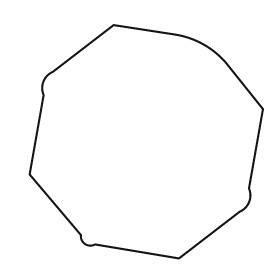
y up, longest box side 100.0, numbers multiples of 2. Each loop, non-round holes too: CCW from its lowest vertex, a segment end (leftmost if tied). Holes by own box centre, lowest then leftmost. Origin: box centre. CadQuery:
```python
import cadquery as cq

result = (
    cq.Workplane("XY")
    .moveTo(14.0, -50.0)
    .lineTo(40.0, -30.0)
    .threePointArc((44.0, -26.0), (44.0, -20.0))
    .lineTo(50.0, 14.0)
    .lineTo(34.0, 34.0)
    .threePointArc((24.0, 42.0), (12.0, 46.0))
    .lineTo(-14.0, 50.0)
    .lineTo(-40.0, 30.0)
    .threePointArc((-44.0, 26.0), (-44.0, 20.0))
    .lineTo(-50.0, -14.0)
    .lineTo(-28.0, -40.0)
    .threePointArc((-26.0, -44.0), (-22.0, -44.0))
    .close()
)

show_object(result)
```